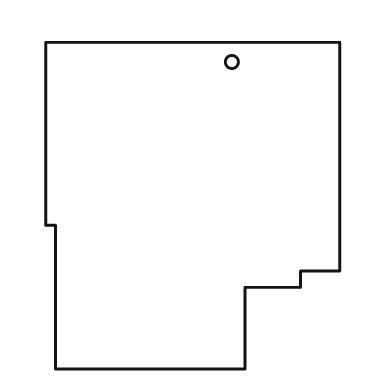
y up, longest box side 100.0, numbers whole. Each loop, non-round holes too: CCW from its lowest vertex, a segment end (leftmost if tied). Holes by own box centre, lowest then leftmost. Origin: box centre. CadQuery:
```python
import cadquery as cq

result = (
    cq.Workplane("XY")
    .moveTo(-42.0, -50.0)
    .lineTo(16.0, -50.0)
    .lineTo(16.0, -25.0)
    .lineTo(33.0, -25.0)
    .lineTo(33.0, -20.0)
    .lineTo(45.0, -20.0)
    .lineTo(45.0, 50.0)
    .lineTo(-45.0, 50.0)
    .lineTo(-45.0, -6.0)
    .lineTo(-42.0, -6.0)
    .close()
    .moveTo(12.0, 44.0)
    .circle(2.0)
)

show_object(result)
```